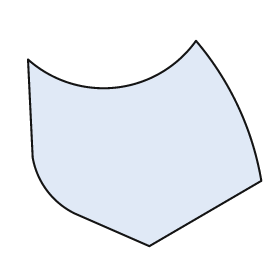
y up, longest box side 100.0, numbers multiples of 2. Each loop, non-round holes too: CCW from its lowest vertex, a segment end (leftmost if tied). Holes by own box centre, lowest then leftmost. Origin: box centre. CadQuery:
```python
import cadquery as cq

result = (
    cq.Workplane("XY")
    .moveTo(2.0, -44.0)
    .lineTo(50.0, -16.0)
    .threePointArc((40.0, 16.0), (22.0, 44.0))
    .threePointArc((-12.0, 24.0), (-50.0, 36.0))
    .lineTo(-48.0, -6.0)
    .threePointArc((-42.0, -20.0), (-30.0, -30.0))
    .close()
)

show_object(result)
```